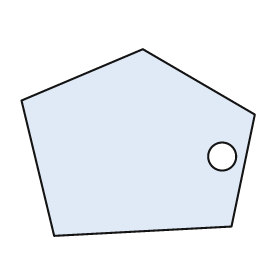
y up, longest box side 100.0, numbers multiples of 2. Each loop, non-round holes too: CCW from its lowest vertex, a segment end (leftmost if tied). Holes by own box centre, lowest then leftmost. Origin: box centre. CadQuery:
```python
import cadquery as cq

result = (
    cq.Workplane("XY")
    .moveTo(-36.0, -40.0)
    .lineTo(40.0, -36.0)
    .lineTo(50.0, 12.0)
    .lineTo(2.0, 40.0)
    .lineTo(-50.0, 18.0)
    .close()
    .moveTo(36.0, -6.0)
    .circle(6.0)
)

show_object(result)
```